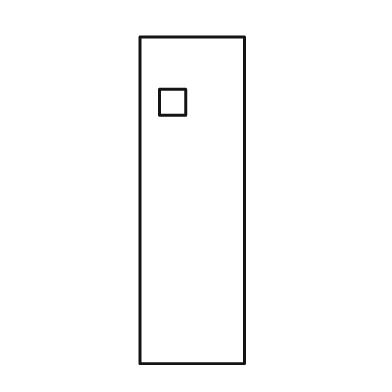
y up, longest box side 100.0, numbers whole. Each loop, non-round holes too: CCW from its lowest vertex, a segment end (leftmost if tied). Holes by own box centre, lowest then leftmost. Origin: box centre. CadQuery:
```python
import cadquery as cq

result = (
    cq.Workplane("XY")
    .moveTo(-16.0, -50.0)
    .lineTo(16.0, -50.0)
    .lineTo(16.0, 50.0)
    .lineTo(-16.0, 50.0)
    .close()
    .moveTo(-10.0, 26.0)
    .lineTo(-2.0, 26.0)
    .lineTo(-2.0, 34.0)
    .lineTo(-10.0, 34.0)
    .close()
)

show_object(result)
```